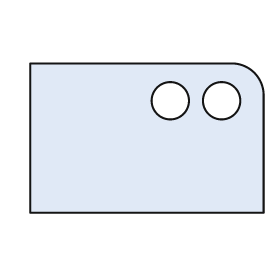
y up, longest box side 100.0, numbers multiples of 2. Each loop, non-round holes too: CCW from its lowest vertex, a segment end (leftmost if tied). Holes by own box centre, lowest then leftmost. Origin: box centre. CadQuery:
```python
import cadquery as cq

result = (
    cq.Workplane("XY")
    .moveTo(-50.0, -32.0)
    .lineTo(50.0, -32.0)
    .lineTo(50.0, 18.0)
    .threePointArc((46.0, 28.0), (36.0, 32.0))
    .lineTo(-50.0, 32.0)
    .close()
    .moveTo(10.0, 16.0)
    .circle(8.0)
    .moveTo(32.0, 16.0)
    .circle(8.0)
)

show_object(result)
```